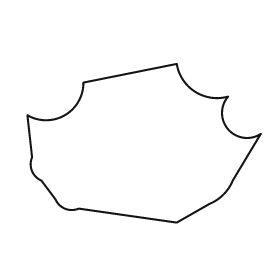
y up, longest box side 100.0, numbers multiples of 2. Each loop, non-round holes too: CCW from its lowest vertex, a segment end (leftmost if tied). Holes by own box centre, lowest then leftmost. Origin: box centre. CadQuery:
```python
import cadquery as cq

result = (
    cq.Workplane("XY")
    .moveTo(14.0, -34.0)
    .lineTo(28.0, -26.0)
    .threePointArc((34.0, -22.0), (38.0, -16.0))
    .lineTo(50.0, 4.0)
    .threePointArc((36.0, 6.0), (36.0, 20.0))
    .threePointArc((22.0, 22.0), (14.0, 34.0))
    .lineTo(-26.0, 26.0)
    .threePointArc((-34.0, 12.0), (-50.0, 12.0))
    .lineTo(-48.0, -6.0)
    .threePointArc((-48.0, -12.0), (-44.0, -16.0))
    .lineTo(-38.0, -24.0)
    .threePointArc((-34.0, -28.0), (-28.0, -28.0))
    .close()
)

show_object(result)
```